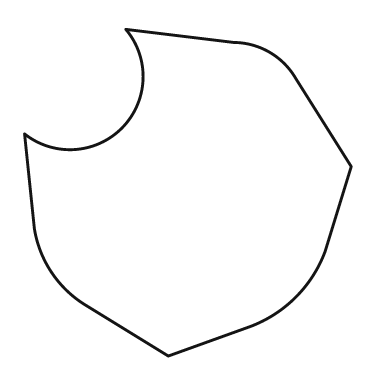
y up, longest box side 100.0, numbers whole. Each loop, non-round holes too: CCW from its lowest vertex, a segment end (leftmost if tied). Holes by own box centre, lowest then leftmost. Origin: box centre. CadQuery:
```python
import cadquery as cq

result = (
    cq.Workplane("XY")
    .moveTo(-6.0, -50.0)
    .lineTo(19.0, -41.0)
    .threePointArc((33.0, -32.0), (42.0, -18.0))
    .lineTo(50.0, 8.0)
    .lineTo(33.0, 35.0)
    .threePointArc((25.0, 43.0), (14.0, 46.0))
    .lineTo(-19.0, 50.0)
    .threePointArc((-20.0, 20.0), (-50.0, 18.0))
    .lineTo(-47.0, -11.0)
    .threePointArc((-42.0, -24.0), (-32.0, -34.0))
    .close()
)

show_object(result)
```